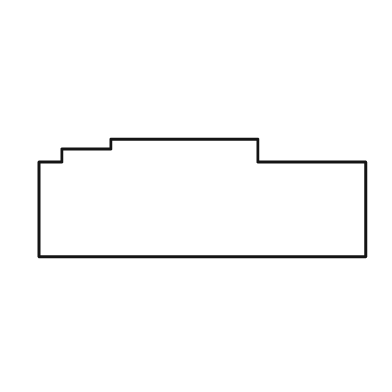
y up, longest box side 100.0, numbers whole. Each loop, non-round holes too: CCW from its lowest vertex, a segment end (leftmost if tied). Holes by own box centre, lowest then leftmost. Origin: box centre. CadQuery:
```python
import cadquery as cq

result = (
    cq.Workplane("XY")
    .moveTo(-50.0, -18.0)
    .lineTo(50.0, -18.0)
    .lineTo(50.0, 11.0)
    .lineTo(17.0, 11.0)
    .lineTo(17.0, 18.0)
    .lineTo(-28.0, 18.0)
    .lineTo(-28.0, 15.0)
    .lineTo(-43.0, 15.0)
    .lineTo(-43.0, 11.0)
    .lineTo(-50.0, 11.0)
    .close()
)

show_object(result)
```